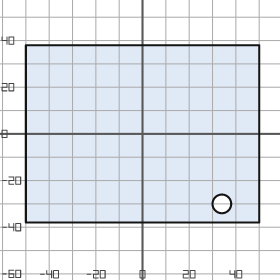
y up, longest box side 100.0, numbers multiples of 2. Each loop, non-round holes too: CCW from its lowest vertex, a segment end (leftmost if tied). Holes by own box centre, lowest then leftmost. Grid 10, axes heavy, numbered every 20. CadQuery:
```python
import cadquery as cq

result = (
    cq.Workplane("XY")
    .moveTo(-50.0, -38.0)
    .lineTo(50.0, -38.0)
    .lineTo(50.0, 38.0)
    .lineTo(-50.0, 38.0)
    .close()
    .moveTo(34.0, -30.0)
    .circle(4.0)
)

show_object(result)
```